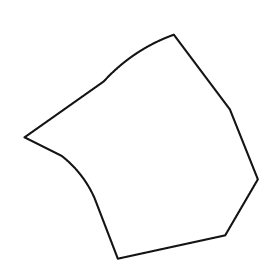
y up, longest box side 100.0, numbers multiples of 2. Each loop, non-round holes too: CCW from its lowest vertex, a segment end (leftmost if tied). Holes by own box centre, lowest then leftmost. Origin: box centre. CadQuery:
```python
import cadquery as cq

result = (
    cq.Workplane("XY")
    .moveTo(-10.0, -48.0)
    .lineTo(36.0, -38.0)
    .lineTo(50.0, -14.0)
    .lineTo(38.0, 16.0)
    .lineTo(14.0, 48.0)
    .threePointArc((-2.0, 40.0), (-16.0, 28.0))
    .lineTo(-50.0, 4.0)
    .lineTo(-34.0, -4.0)
    .threePointArc((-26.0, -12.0), (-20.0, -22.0))
    .close()
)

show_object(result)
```